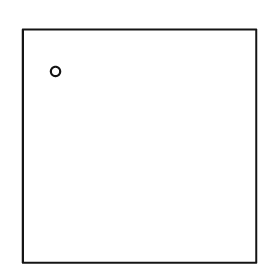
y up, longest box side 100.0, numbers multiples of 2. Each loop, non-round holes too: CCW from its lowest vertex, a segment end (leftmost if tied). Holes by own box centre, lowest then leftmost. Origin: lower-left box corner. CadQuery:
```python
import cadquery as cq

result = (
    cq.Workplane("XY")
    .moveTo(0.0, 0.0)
    .lineTo(100.0, 0.0)
    .lineTo(100.0, 100.0)
    .lineTo(0.0, 100.0)
    .close()
    .moveTo(14.0, 82.0)
    .circle(2.0)
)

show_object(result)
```